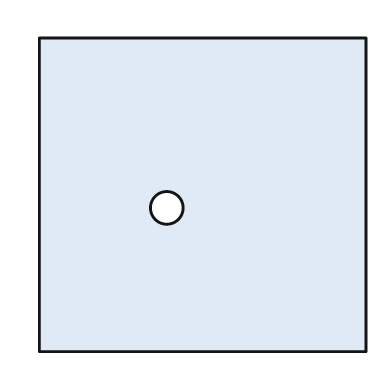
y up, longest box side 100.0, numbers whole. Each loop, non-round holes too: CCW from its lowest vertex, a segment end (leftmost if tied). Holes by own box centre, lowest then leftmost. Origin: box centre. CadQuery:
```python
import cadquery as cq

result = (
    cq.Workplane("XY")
    .moveTo(-50.0, -48.0)
    .lineTo(50.0, -48.0)
    .lineTo(50.0, 48.0)
    .lineTo(-50.0, 48.0)
    .close()
    .moveTo(-11.0, -4.0)
    .circle(5.0)
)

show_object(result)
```